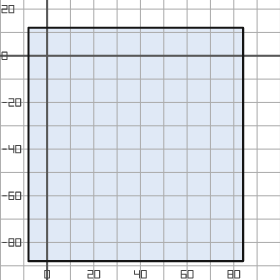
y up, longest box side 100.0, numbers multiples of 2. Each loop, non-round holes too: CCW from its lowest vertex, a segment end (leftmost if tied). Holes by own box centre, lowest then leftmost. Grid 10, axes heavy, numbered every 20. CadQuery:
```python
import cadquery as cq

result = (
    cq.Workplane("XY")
    .moveTo(-8.0, -88.0)
    .lineTo(84.0, -88.0)
    .lineTo(84.0, 12.0)
    .lineTo(-8.0, 12.0)
    .close()
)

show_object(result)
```